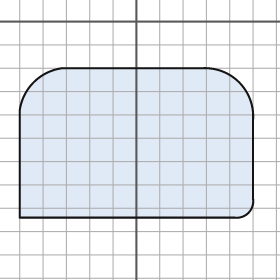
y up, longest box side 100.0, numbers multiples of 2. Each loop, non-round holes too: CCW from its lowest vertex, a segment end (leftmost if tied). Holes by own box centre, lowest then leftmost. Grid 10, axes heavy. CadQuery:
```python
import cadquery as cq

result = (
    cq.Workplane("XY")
    .moveTo(-50.0, -84.0)
    .lineTo(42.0, -84.0)
    .threePointArc((48.0, -82.0), (50.0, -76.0))
    .lineTo(50.0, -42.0)
    .threePointArc((44.0, -26.0), (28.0, -20.0))
    .lineTo(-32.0, -20.0)
    .threePointArc((-44.0, -26.0), (-50.0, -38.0))
    .close()
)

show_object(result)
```